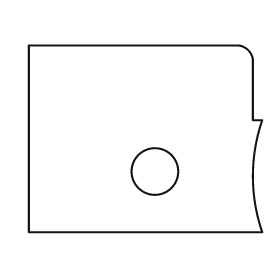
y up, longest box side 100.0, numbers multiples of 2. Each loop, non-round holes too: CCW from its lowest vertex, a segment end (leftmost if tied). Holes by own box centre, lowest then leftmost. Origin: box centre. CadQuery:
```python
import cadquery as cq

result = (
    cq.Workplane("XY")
    .moveTo(-50.0, -40.0)
    .lineTo(50.0, -40.0)
    .threePointArc((46.0, -16.0), (50.0, 8.0))
    .lineTo(46.0, 8.0)
    .lineTo(46.0, 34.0)
    .threePointArc((44.0, 38.0), (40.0, 40.0))
    .lineTo(-50.0, 40.0)
    .close()
    .moveTo(4.0, -14.0)
    .circle(10.0)
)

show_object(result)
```